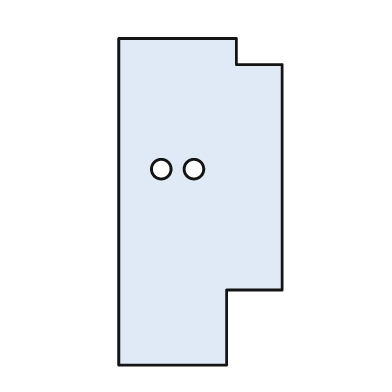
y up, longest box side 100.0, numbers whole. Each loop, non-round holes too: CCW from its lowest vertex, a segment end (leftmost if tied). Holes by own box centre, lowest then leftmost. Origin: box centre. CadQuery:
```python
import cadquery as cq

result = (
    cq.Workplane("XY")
    .moveTo(-25.0, -50.0)
    .lineTo(8.0, -50.0)
    .lineTo(8.0, -27.0)
    .lineTo(25.0, -27.0)
    .lineTo(25.0, 42.0)
    .lineTo(11.0, 42.0)
    .lineTo(11.0, 50.0)
    .lineTo(-25.0, 50.0)
    .close()
    .moveTo(-12.0, 10.0)
    .circle(3.0)
    .moveTo(-2.0, 10.0)
    .circle(3.0)
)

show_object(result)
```